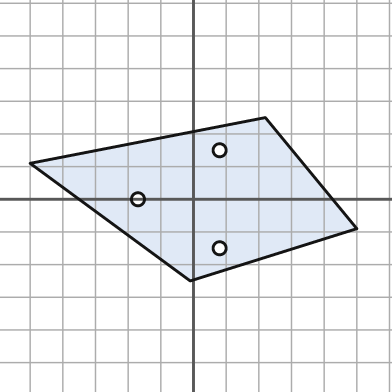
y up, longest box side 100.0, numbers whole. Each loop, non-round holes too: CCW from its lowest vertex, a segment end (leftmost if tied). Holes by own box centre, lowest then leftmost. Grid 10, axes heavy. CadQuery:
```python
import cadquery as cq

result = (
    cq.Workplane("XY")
    .moveTo(-1.0, -25.0)
    .lineTo(50.0, -9.0)
    .lineTo(22.0, 25.0)
    .lineTo(-50.0, 11.0)
    .close()
    .moveTo(8.0, -15.0)
    .circle(2.0)
    .moveTo(-17.0, 0.0)
    .circle(2.0)
    .moveTo(8.0, 15.0)
    .circle(2.0)
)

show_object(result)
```